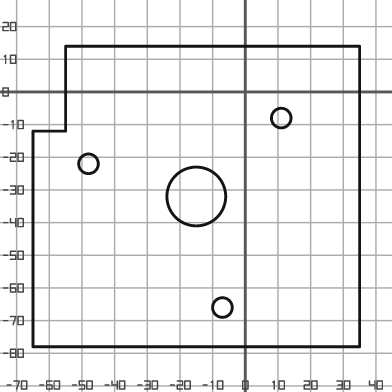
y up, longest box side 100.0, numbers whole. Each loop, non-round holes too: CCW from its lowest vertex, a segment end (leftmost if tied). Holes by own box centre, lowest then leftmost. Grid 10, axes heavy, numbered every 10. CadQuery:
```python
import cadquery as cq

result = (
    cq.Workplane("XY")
    .moveTo(-65.0, -78.0)
    .lineTo(35.0, -78.0)
    .lineTo(35.0, 14.0)
    .lineTo(-55.0, 14.0)
    .lineTo(-55.0, -12.0)
    .lineTo(-65.0, -12.0)
    .close()
    .moveTo(-7.0, -66.0)
    .circle(3.0)
    .moveTo(-15.0, -32.0)
    .circle(9.0)
    .moveTo(-48.0, -22.0)
    .circle(3.0)
    .moveTo(11.0, -8.0)
    .circle(3.0)
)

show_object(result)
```